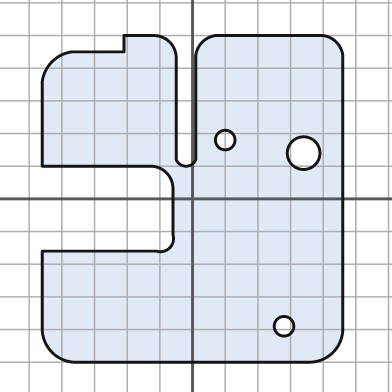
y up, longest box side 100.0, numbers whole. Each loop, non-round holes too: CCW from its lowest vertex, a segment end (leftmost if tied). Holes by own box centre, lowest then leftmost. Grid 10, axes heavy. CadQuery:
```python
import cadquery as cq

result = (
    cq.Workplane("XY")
    .moveTo(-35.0, -50.0)
    .lineTo(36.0, -50.0)
    .threePointArc((43.0, -47.0), (46.0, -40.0))
    .lineTo(46.0, 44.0)
    .threePointArc((44.0, 48.0), (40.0, 50.0))
    .lineTo(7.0, 50.0)
    .threePointArc((3.0, 48.0), (1.0, 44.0))
    .lineTo(1.0, 12.0)
    .threePointArc((-2.0, 10.0), (-5.0, 12.0))
    .lineTo(-5.0, 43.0)
    .threePointArc((-7.0, 48.0), (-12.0, 50.0))
    .lineTo(-21.0, 50.0)
    .lineTo(-21.0, 45.0)
    .lineTo(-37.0, 45.0)
    .threePointArc((-43.0, 42.0), (-46.0, 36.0))
    .lineTo(-46.0, 10.0)
    .lineTo(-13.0, 10.0)
    .threePointArc((-8.0, 8.0), (-6.0, 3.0))
    .lineTo(-6.0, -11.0)
    .threePointArc((-7.0, -15.0), (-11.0, -16.0))
    .lineTo(-46.0, -16.0)
    .lineTo(-46.0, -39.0)
    .threePointArc((-43.0, -47.0), (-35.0, -50.0))
    .close()
    .moveTo(28.0, -39.0)
    .circle(3.0)
    .moveTo(34.0, 14.0)
    .circle(5.0)
    .moveTo(10.0, 18.0)
    .circle(3.0)
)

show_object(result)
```